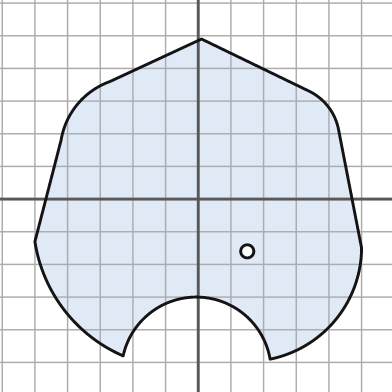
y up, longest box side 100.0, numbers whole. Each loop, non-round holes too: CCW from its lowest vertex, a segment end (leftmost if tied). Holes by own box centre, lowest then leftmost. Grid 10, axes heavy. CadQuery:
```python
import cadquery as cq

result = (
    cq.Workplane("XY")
    .moveTo(22.0, -49.0)
    .threePointArc((42.0, -37.0), (50.0, -15.0))
    .lineTo(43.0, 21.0)
    .threePointArc((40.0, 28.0), (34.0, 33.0))
    .lineTo(1.0, 49.0)
    .lineTo(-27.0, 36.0)
    .threePointArc((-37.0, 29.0), (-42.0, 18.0))
    .lineTo(-50.0, -13.0)
    .threePointArc((-41.0, -34.0), (-23.0, -48.0))
    .threePointArc((0.0, -30.0), (22.0, -49.0))
    .close()
    .moveTo(15.0, -16.0)
    .circle(2.0)
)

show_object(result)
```